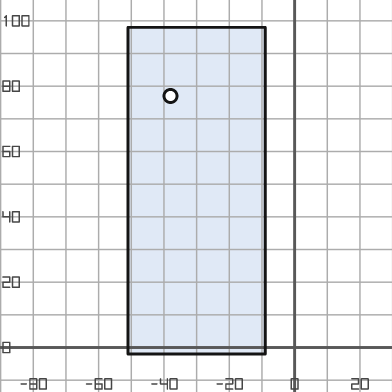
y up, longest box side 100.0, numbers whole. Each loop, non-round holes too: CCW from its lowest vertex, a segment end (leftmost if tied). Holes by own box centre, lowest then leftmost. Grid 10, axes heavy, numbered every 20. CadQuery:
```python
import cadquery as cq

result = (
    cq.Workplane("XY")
    .moveTo(-51.0, -2.0)
    .lineTo(-9.0, -2.0)
    .lineTo(-9.0, 98.0)
    .lineTo(-51.0, 98.0)
    .close()
    .moveTo(-38.0, 77.0)
    .circle(2.0)
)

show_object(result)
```